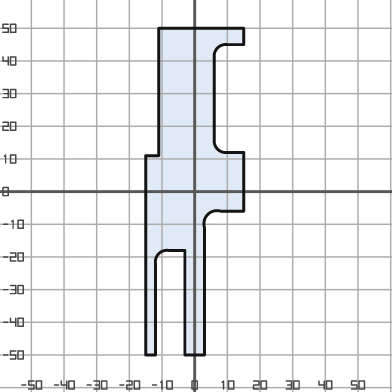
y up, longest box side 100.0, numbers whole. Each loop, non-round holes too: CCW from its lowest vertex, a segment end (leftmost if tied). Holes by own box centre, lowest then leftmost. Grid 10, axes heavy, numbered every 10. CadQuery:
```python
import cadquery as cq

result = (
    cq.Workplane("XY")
    .moveTo(-15.0, -50.0)
    .lineTo(-12.0, -50.0)
    .lineTo(-12.0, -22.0)
    .threePointArc((-11.0, -19.0), (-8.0, -18.0))
    .lineTo(-3.0, -18.0)
    .lineTo(-3.0, -50.0)
    .lineTo(3.0, -50.0)
    .lineTo(3.0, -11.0)
    .threePointArc((4.0, -7.0), (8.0, -6.0))
    .lineTo(15.0, -6.0)
    .lineTo(15.0, 12.0)
    .lineTo(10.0, 12.0)
    .threePointArc((7.0, 13.0), (6.0, 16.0))
    .lineTo(6.0, 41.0)
    .threePointArc((7.0, 44.0), (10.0, 45.0))
    .lineTo(15.0, 45.0)
    .lineTo(15.0, 50.0)
    .lineTo(-11.0, 50.0)
    .lineTo(-11.0, 11.0)
    .lineTo(-15.0, 11.0)
    .close()
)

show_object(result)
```